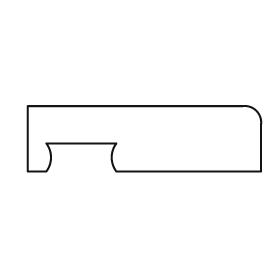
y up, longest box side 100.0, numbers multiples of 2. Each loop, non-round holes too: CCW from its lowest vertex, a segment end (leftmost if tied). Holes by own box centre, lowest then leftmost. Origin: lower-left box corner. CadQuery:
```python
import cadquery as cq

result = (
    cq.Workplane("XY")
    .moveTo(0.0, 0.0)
    .lineTo(8.0, 0.0)
    .threePointArc((10.0, 6.0), (8.0, 12.0))
    .lineTo(38.0, 12.0)
    .threePointArc((36.0, 6.0), (38.0, 0.0))
    .lineTo(100.0, 0.0)
    .lineTo(100.0, 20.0)
    .threePointArc((98.0, 26.0), (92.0, 28.0))
    .lineTo(0.0, 28.0)
    .close()
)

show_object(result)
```